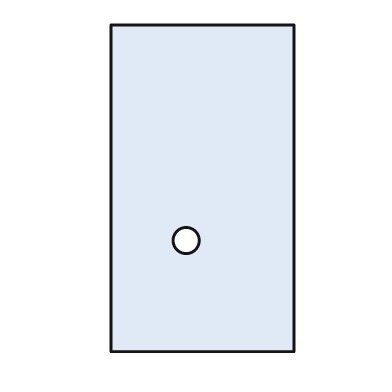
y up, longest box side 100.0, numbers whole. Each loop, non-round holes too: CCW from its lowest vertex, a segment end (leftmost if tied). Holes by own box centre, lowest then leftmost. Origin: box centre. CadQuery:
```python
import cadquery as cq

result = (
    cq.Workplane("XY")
    .moveTo(-28.0, -50.0)
    .lineTo(28.0, -50.0)
    .lineTo(28.0, 50.0)
    .lineTo(-28.0, 50.0)
    .close()
    .moveTo(-5.0, -16.0)
    .circle(4.0)
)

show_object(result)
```